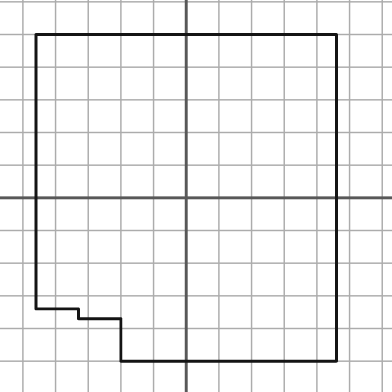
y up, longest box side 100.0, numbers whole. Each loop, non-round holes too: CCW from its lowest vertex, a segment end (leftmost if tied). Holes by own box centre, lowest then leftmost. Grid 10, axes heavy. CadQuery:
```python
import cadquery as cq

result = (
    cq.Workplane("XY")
    .moveTo(-20.0, -50.0)
    .lineTo(46.0, -50.0)
    .lineTo(46.0, 50.0)
    .lineTo(-46.0, 50.0)
    .lineTo(-46.0, -34.0)
    .lineTo(-33.0, -34.0)
    .lineTo(-33.0, -37.0)
    .lineTo(-20.0, -37.0)
    .close()
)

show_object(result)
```